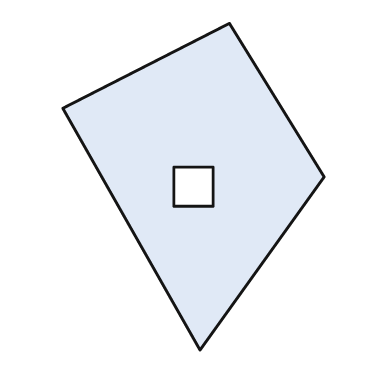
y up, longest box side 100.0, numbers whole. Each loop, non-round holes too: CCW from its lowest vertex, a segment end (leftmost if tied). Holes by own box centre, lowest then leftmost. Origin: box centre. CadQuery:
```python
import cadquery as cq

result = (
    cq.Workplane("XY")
    .moveTo(2.0, -50.0)
    .lineTo(40.0, 3.0)
    .lineTo(11.0, 50.0)
    .lineTo(-40.0, 24.0)
    .close()
    .moveTo(-6.0, -6.0)
    .lineTo(6.0, -6.0)
    .lineTo(6.0, 6.0)
    .lineTo(-6.0, 6.0)
    .close()
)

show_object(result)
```